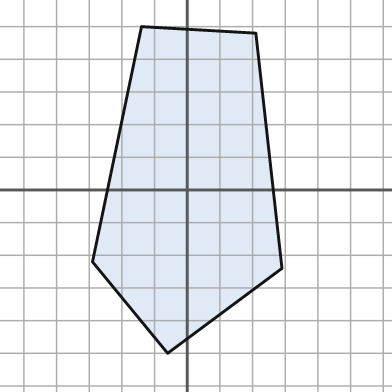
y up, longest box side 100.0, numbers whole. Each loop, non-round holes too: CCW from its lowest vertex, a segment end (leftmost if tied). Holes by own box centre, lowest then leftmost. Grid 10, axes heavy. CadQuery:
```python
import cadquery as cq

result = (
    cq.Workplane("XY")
    .moveTo(-6.0, -50.0)
    .lineTo(29.0, -24.0)
    .lineTo(21.0, 48.0)
    .lineTo(-14.0, 50.0)
    .lineTo(-29.0, -22.0)
    .close()
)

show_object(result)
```